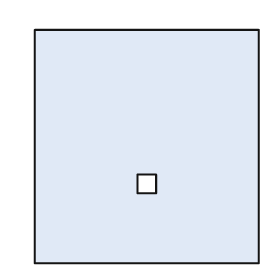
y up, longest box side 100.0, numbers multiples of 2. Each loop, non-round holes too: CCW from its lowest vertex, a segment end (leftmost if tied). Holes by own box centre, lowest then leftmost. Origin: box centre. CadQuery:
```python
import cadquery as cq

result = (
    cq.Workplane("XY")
    .moveTo(-48.0, -50.0)
    .lineTo(48.0, -50.0)
    .lineTo(48.0, 50.0)
    .lineTo(-48.0, 50.0)
    .close()
    .moveTo(-4.0, -20.0)
    .lineTo(4.0, -20.0)
    .lineTo(4.0, -12.0)
    .lineTo(-4.0, -12.0)
    .close()
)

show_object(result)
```